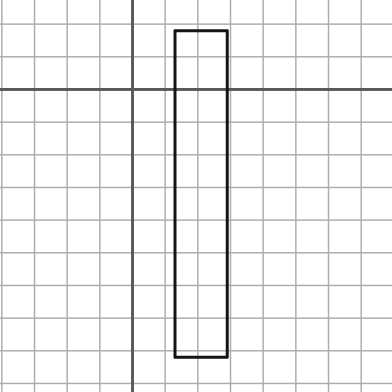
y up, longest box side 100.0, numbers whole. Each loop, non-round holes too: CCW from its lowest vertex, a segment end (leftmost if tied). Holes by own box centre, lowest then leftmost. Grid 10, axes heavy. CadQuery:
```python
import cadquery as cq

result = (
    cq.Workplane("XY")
    .moveTo(13.0, -82.0)
    .lineTo(29.0, -82.0)
    .lineTo(29.0, 18.0)
    .lineTo(13.0, 18.0)
    .close()
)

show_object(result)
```